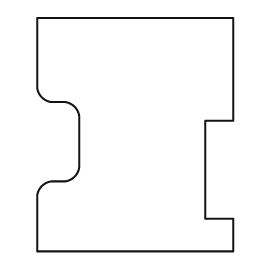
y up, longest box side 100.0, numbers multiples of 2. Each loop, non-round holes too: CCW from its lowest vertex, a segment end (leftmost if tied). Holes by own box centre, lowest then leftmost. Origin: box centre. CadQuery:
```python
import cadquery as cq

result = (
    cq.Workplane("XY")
    .moveTo(-42.0, -50.0)
    .lineTo(42.0, -50.0)
    .lineTo(42.0, -36.0)
    .lineTo(30.0, -36.0)
    .lineTo(30.0, 6.0)
    .lineTo(42.0, 6.0)
    .lineTo(42.0, 50.0)
    .lineTo(-42.0, 50.0)
    .lineTo(-42.0, 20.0)
    .threePointArc((-40.0, 16.0), (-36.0, 14.0))
    .lineTo(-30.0, 14.0)
    .threePointArc((-26.0, 12.0), (-24.0, 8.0))
    .lineTo(-24.0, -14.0)
    .threePointArc((-26.0, -18.0), (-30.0, -20.0))
    .lineTo(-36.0, -20.0)
    .threePointArc((-40.0, -22.0), (-42.0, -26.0))
    .close()
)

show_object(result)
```